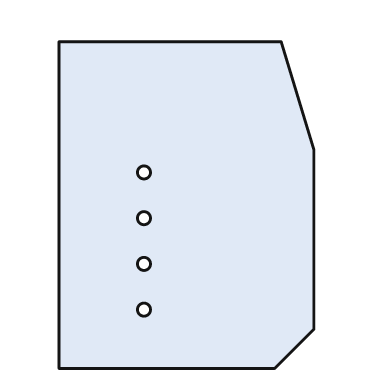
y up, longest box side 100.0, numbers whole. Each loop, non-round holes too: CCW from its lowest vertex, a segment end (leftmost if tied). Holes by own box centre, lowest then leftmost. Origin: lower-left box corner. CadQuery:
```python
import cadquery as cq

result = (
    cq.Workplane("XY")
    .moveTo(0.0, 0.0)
    .lineTo(66.0, 0.0)
    .lineTo(78.0, 12.0)
    .lineTo(78.0, 67.0)
    .lineTo(68.0, 100.0)
    .lineTo(0.0, 100.0)
    .close()
    .moveTo(26.0, 18.0)
    .circle(2.0)
    .moveTo(26.0, 32.0)
    .circle(2.0)
    .moveTo(26.0, 46.0)
    .circle(2.0)
    .moveTo(26.0, 60.0)
    .circle(2.0)
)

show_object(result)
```